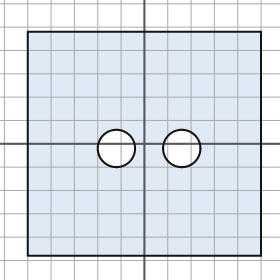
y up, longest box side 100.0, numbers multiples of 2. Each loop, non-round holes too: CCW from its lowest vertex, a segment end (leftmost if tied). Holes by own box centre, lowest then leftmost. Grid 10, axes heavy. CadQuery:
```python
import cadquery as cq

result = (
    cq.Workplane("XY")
    .moveTo(-50.0, -48.0)
    .lineTo(50.0, -48.0)
    .lineTo(50.0, 48.0)
    .lineTo(-50.0, 48.0)
    .close()
    .moveTo(-12.0, -2.0)
    .circle(8.0)
    .moveTo(16.0, -2.0)
    .circle(8.0)
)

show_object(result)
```